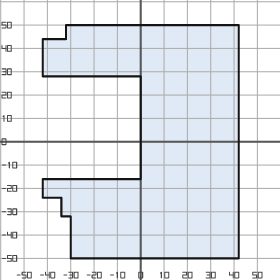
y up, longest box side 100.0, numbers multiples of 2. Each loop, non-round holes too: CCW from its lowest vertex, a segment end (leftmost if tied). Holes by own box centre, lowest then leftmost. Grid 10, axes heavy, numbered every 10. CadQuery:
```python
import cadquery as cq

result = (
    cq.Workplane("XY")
    .moveTo(-30.0, -50.0)
    .lineTo(42.0, -50.0)
    .lineTo(42.0, 50.0)
    .lineTo(-32.0, 50.0)
    .lineTo(-32.0, 44.0)
    .lineTo(-42.0, 44.0)
    .lineTo(-42.0, 28.0)
    .lineTo(0.0, 28.0)
    .lineTo(0.0, -16.0)
    .lineTo(-42.0, -16.0)
    .lineTo(-42.0, -24.0)
    .lineTo(-34.0, -24.0)
    .lineTo(-34.0, -32.0)
    .lineTo(-30.0, -32.0)
    .close()
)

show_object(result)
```